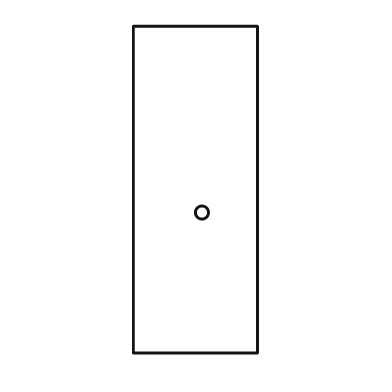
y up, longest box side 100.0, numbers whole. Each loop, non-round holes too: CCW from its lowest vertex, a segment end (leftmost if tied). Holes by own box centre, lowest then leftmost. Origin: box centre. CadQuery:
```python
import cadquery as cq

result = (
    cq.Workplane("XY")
    .moveTo(-19.0, -50.0)
    .lineTo(19.0, -50.0)
    .lineTo(19.0, 50.0)
    .lineTo(-19.0, 50.0)
    .close()
    .moveTo(2.0, -7.0)
    .circle(2.0)
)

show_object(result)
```